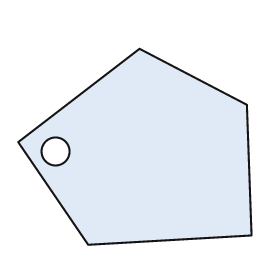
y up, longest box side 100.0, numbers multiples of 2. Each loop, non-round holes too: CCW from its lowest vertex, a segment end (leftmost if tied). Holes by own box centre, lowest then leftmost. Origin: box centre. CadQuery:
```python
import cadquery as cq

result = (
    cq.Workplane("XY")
    .moveTo(-20.0, -42.0)
    .lineTo(50.0, -38.0)
    .lineTo(48.0, 18.0)
    .lineTo(2.0, 42.0)
    .lineTo(-50.0, 2.0)
    .close()
    .moveTo(-34.0, -2.0)
    .circle(6.0)
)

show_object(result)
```